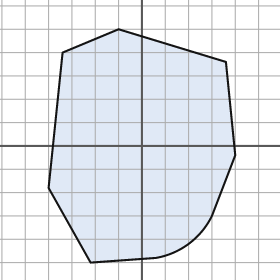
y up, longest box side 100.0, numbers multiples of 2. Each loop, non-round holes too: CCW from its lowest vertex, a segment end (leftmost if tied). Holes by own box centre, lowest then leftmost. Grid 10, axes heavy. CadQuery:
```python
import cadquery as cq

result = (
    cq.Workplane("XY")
    .moveTo(-22.0, -50.0)
    .lineTo(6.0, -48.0)
    .threePointArc((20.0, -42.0), (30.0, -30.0))
    .lineTo(40.0, -4.0)
    .lineTo(36.0, 36.0)
    .lineTo(-10.0, 50.0)
    .lineTo(-34.0, 40.0)
    .lineTo(-40.0, -18.0)
    .close()
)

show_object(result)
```